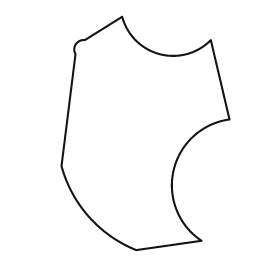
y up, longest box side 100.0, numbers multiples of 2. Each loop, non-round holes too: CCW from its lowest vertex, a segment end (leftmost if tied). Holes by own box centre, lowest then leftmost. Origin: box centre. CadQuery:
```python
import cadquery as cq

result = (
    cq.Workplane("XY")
    .moveTo(-4.0, -50.0)
    .lineTo(24.0, -46.0)
    .threePointArc((12.0, -16.0), (36.0, 6.0))
    .lineTo(28.0, 40.0)
    .threePointArc((6.0, 34.0), (-10.0, 50.0))
    .lineTo(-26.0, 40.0)
    .threePointArc((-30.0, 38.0), (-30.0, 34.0))
    .lineTo(-36.0, -14.0)
    .threePointArc((-24.0, -36.0), (-4.0, -50.0))
    .close()
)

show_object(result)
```